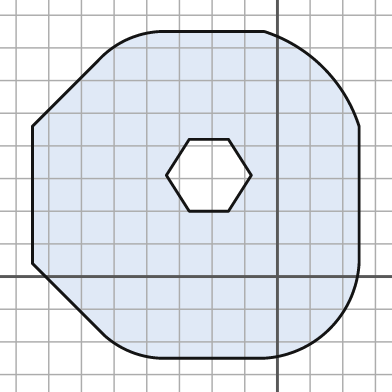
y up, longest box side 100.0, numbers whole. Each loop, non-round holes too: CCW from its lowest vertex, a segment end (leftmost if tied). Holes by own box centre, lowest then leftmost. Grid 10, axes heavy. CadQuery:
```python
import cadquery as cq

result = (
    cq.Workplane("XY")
    .moveTo(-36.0, -25.0)
    .lineTo(-4.0, -25.0)
    .threePointArc((16.0, -16.0), (25.0, 4.0))
    .lineTo(25.0, 46.0)
    .threePointArc((14.0, 64.0), (-4.0, 75.0))
    .lineTo(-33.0, 75.0)
    .threePointArc((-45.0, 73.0), (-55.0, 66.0))
    .lineTo(-75.0, 46.0)
    .lineTo(-75.0, 4.0)
    .lineTo(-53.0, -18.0)
    .threePointArc((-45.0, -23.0), (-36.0, -25.0))
    .close()
    .moveTo(-27.0, 20.0)
    .lineTo(-15.0, 20.0)
    .lineTo(-8.0, 31.0)
    .lineTo(-15.0, 42.0)
    .lineTo(-27.0, 42.0)
    .lineTo(-34.0, 31.0)
    .close()
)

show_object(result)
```